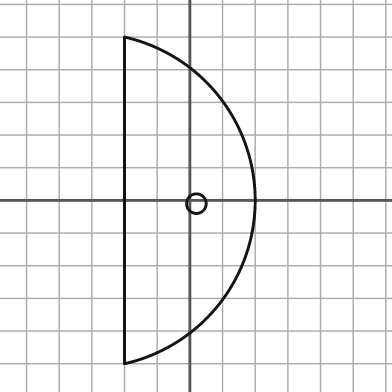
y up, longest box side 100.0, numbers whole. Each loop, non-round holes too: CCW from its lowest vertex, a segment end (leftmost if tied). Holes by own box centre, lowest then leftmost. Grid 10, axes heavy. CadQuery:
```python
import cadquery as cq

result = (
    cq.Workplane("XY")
    .moveTo(-20.0, -50.0)
    .threePointArc((20.0, 0.0), (-20.0, 50.0))
    .close()
    .moveTo(2.0, -1.0)
    .circle(3.0)
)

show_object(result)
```